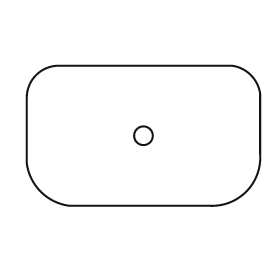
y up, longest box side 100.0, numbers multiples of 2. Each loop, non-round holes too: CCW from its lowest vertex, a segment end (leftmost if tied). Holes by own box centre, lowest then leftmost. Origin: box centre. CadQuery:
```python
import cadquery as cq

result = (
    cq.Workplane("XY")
    .moveTo(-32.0, -30.0)
    .lineTo(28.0, -30.0)
    .threePointArc((44.0, -24.0), (50.0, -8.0))
    .lineTo(50.0, 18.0)
    .threePointArc((46.0, 26.0), (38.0, 30.0))
    .lineTo(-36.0, 30.0)
    .threePointArc((-46.0, 26.0), (-50.0, 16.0))
    .lineTo(-50.0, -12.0)
    .threePointArc((-44.0, -24.0), (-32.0, -30.0))
    .close()
    .moveTo(0.0, 0.0)
    .circle(4.0)
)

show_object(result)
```